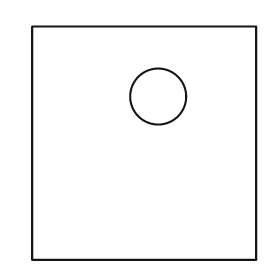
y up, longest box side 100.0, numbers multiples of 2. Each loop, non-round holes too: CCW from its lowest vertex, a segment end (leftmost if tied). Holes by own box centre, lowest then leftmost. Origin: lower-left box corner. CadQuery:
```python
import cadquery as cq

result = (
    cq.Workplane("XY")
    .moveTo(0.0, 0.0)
    .lineTo(96.0, 0.0)
    .lineTo(96.0, 100.0)
    .lineTo(0.0, 100.0)
    .close()
    .moveTo(54.0, 70.0)
    .circle(12.0)
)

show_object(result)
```